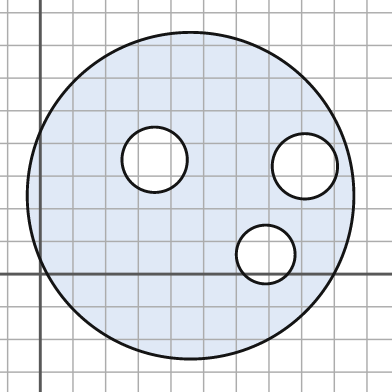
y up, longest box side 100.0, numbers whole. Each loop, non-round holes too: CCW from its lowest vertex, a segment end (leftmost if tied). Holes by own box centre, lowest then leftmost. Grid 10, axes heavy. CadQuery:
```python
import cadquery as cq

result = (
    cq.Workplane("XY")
    .moveTo(46.0, 24.0)
    .circle(50.0)
    .moveTo(69.0, 6.0)
    .circle(9.0)
    .moveTo(81.0, 33.0)
    .circle(10.0)
    .moveTo(35.0, 35.0)
    .circle(10.0)
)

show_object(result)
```